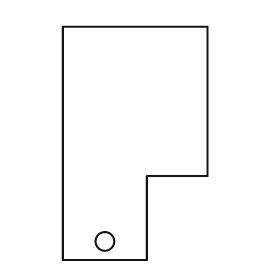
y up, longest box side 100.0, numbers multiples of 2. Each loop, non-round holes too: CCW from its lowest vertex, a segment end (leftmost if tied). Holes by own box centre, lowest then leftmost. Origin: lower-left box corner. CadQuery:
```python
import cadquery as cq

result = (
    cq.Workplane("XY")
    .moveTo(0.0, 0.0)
    .lineTo(36.0, 0.0)
    .lineTo(36.0, 36.0)
    .lineTo(62.0, 36.0)
    .lineTo(62.0, 100.0)
    .lineTo(0.0, 100.0)
    .close()
    .moveTo(18.0, 8.0)
    .circle(4.0)
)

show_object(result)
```